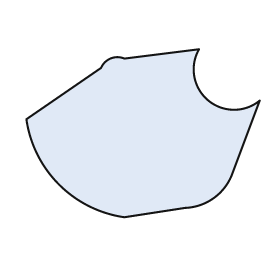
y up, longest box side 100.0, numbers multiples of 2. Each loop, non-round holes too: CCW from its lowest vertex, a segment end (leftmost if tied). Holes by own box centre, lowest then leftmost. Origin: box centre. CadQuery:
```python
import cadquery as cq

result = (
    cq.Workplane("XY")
    .moveTo(-8.0, -36.0)
    .lineTo(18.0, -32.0)
    .threePointArc((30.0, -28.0), (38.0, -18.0))
    .lineTo(50.0, 14.0)
    .threePointArc((28.0, 14.0), (24.0, 36.0))
    .lineTo(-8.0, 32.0)
    .threePointArc((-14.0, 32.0), (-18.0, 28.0))
    .lineTo(-50.0, 6.0)
    .threePointArc((-36.0, -22.0), (-8.0, -36.0))
    .close()
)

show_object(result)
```